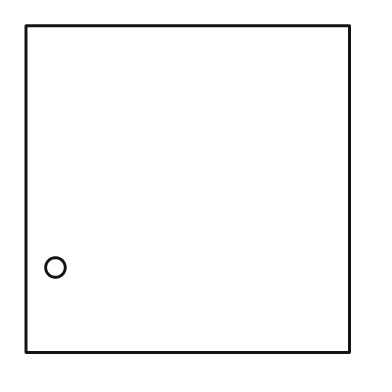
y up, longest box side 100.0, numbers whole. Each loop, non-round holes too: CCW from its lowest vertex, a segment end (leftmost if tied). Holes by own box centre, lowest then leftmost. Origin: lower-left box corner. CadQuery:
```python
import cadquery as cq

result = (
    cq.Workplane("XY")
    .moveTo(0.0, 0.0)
    .lineTo(99.0, 0.0)
    .lineTo(99.0, 100.0)
    .lineTo(0.0, 100.0)
    .close()
    .moveTo(9.0, 26.0)
    .circle(3.0)
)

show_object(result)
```